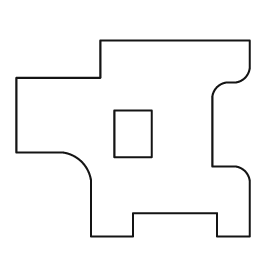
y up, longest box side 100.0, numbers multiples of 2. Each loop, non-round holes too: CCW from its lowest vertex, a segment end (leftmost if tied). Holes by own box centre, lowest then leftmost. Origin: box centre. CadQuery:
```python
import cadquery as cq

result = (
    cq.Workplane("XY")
    .moveTo(-18.0, -42.0)
    .lineTo(0.0, -42.0)
    .lineTo(0.0, -32.0)
    .lineTo(36.0, -32.0)
    .lineTo(36.0, -42.0)
    .lineTo(50.0, -42.0)
    .lineTo(50.0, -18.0)
    .threePointArc((48.0, -14.0), (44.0, -12.0))
    .lineTo(34.0, -12.0)
    .lineTo(34.0, 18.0)
    .threePointArc((36.0, 22.0), (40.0, 24.0))
    .lineTo(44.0, 24.0)
    .threePointArc((48.0, 26.0), (50.0, 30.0))
    .lineTo(50.0, 42.0)
    .lineTo(-14.0, 42.0)
    .lineTo(-14.0, 26.0)
    .lineTo(-50.0, 26.0)
    .lineTo(-50.0, -6.0)
    .lineTo(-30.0, -6.0)
    .threePointArc((-22.0, -10.0), (-18.0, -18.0))
    .close()
    .moveTo(-8.0, -8.0)
    .lineTo(8.0, -8.0)
    .lineTo(8.0, 12.0)
    .lineTo(-8.0, 12.0)
    .close()
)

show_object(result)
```